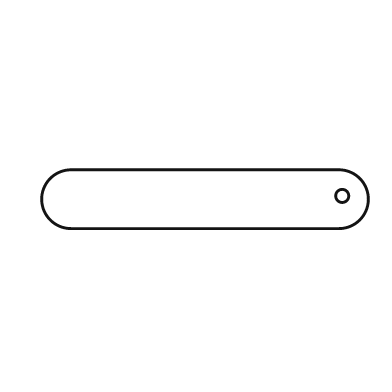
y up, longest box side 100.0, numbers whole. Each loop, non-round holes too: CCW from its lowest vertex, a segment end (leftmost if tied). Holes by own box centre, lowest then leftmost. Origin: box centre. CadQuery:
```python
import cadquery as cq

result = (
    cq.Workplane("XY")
    .moveTo(-41.0, -9.0)
    .lineTo(41.0, -9.0)
    .threePointArc((50.0, 0.0), (41.0, 9.0))
    .lineTo(-41.0, 9.0)
    .threePointArc((-50.0, 0.0), (-41.0, -9.0))
    .close()
    .moveTo(42.0, 1.0)
    .circle(2.0)
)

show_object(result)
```